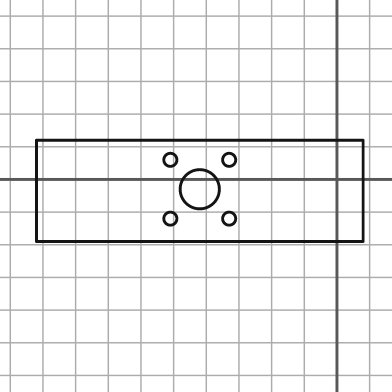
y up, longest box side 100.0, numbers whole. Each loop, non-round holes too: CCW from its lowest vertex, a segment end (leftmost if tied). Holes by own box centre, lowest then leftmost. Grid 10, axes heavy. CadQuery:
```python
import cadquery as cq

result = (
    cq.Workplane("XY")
    .moveTo(-92.0, -19.0)
    .lineTo(8.0, -19.0)
    .lineTo(8.0, 12.0)
    .lineTo(-92.0, 12.0)
    .close()
    .moveTo(-51.0, -12.0)
    .circle(2.0)
    .moveTo(-33.0, -12.0)
    .circle(2.0)
    .moveTo(-42.0, -3.0)
    .circle(6.0)
    .moveTo(-51.0, 6.0)
    .circle(2.0)
    .moveTo(-33.0, 6.0)
    .circle(2.0)
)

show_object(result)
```